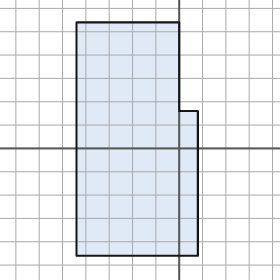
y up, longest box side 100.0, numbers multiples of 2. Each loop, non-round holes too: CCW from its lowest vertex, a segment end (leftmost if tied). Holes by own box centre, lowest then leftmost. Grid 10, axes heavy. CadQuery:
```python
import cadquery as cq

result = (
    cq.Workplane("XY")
    .moveTo(-44.0, -46.0)
    .lineTo(8.0, -46.0)
    .lineTo(8.0, 16.0)
    .lineTo(0.0, 16.0)
    .lineTo(0.0, 54.0)
    .lineTo(-44.0, 54.0)
    .close()
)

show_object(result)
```